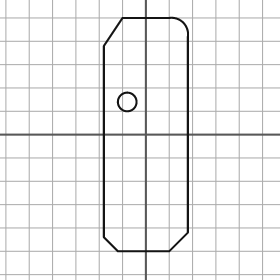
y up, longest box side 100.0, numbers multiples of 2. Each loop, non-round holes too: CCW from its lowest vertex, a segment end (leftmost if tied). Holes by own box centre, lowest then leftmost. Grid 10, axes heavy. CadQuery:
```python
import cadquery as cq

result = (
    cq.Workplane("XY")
    .moveTo(-12.0, -50.0)
    .lineTo(10.0, -50.0)
    .lineTo(18.0, -42.0)
    .lineTo(18.0, 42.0)
    .threePointArc((16.0, 48.0), (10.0, 50.0))
    .lineTo(-10.0, 50.0)
    .lineTo(-18.0, 38.0)
    .lineTo(-18.0, -44.0)
    .close()
    .moveTo(-8.0, 14.0)
    .circle(4.0)
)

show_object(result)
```